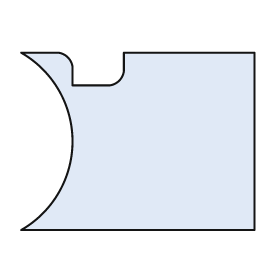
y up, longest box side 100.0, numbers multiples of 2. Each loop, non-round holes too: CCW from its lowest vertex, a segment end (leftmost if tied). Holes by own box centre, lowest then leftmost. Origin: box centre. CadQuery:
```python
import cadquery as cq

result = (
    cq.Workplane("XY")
    .moveTo(-50.0, -38.0)
    .lineTo(50.0, -38.0)
    .lineTo(50.0, 38.0)
    .lineTo(-6.0, 38.0)
    .lineTo(-6.0, 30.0)
    .threePointArc((-8.0, 26.0), (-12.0, 24.0))
    .lineTo(-28.0, 24.0)
    .lineTo(-28.0, 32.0)
    .threePointArc((-30.0, 36.0), (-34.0, 38.0))
    .lineTo(-50.0, 38.0)
    .threePointArc((-28.0, 0.0), (-50.0, -38.0))
    .close()
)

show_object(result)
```